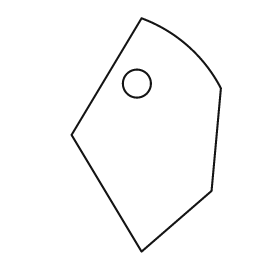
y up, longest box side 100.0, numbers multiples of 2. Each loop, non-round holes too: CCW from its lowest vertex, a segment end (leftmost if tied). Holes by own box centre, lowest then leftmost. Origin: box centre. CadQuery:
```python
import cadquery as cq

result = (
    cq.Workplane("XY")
    .moveTo(-2.0, -50.0)
    .lineTo(28.0, -24.0)
    .lineTo(32.0, 20.0)
    .threePointArc((18.0, 38.0), (-2.0, 50.0))
    .lineTo(-32.0, 0.0)
    .close()
    .moveTo(-4.0, 22.0)
    .circle(6.0)
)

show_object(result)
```